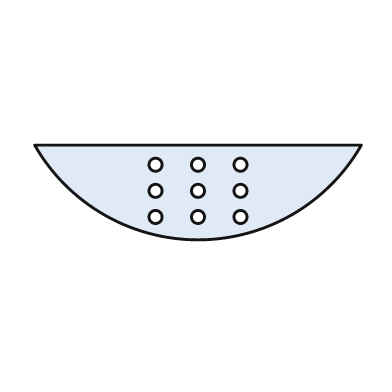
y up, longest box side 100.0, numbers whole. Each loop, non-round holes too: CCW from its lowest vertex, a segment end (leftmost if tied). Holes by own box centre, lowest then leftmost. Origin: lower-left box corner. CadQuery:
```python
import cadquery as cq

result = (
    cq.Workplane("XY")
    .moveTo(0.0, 29.0)
    .threePointArc((50.0, 0.0), (100.0, 29.0))
    .close()
    .moveTo(37.0, 7.0)
    .circle(2.0)
    .moveTo(50.0, 7.0)
    .circle(2.0)
    .moveTo(63.0, 7.0)
    .circle(2.0)
    .moveTo(37.0, 15.0)
    .circle(2.0)
    .moveTo(50.0, 15.0)
    .circle(2.0)
    .moveTo(63.0, 15.0)
    .circle(2.0)
    .moveTo(37.0, 23.0)
    .circle(2.0)
    .moveTo(50.0, 23.0)
    .circle(2.0)
    .moveTo(63.0, 23.0)
    .circle(2.0)
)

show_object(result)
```